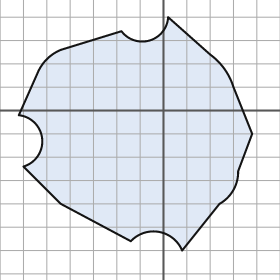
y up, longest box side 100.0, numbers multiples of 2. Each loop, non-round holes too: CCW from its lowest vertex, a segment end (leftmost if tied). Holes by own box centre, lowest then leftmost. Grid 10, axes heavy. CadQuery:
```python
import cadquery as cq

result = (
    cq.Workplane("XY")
    .moveTo(8.0, -60.0)
    .lineTo(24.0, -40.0)
    .threePointArc((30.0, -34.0), (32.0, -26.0))
    .lineTo(38.0, -10.0)
    .lineTo(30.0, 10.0)
    .threePointArc((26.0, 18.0), (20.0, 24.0))
    .lineTo(2.0, 40.0)
    .threePointArc((-6.0, 30.0), (-18.0, 34.0))
    .lineTo(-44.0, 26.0)
    .threePointArc((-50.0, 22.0), (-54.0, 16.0))
    .lineTo(-62.0, -2.0)
    .threePointArc((-52.0, -12.0), (-60.0, -24.0))
    .lineTo(-44.0, -40.0)
    .lineTo(-14.0, -56.0)
    .threePointArc((-2.0, -52.0), (8.0, -60.0))
    .close()
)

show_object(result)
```